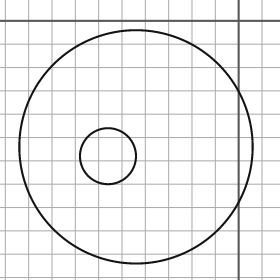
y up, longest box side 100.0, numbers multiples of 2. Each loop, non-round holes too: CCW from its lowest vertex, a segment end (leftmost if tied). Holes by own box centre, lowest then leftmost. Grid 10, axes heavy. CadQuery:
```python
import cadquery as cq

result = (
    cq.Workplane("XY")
    .moveTo(-44.0, -54.0)
    .circle(50.0)
    .moveTo(-56.0, -58.0)
    .circle(12.0)
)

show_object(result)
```